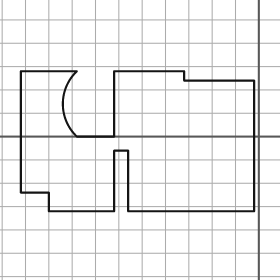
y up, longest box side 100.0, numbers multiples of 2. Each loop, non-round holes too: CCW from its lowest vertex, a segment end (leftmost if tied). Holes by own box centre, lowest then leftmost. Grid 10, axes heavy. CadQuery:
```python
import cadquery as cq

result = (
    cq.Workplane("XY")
    .moveTo(-90.0, -32.0)
    .lineTo(-62.0, -32.0)
    .lineTo(-62.0, -6.0)
    .lineTo(-56.0, -6.0)
    .lineTo(-56.0, -32.0)
    .lineTo(-2.0, -32.0)
    .lineTo(-2.0, 24.0)
    .lineTo(-32.0, 24.0)
    .lineTo(-32.0, 28.0)
    .lineTo(-62.0, 28.0)
    .lineTo(-62.0, 0.0)
    .lineTo(-78.0, 0.0)
    .threePointArc((-84.0, 14.0), (-78.0, 28.0))
    .lineTo(-102.0, 28.0)
    .lineTo(-102.0, -24.0)
    .lineTo(-90.0, -24.0)
    .close()
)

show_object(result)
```